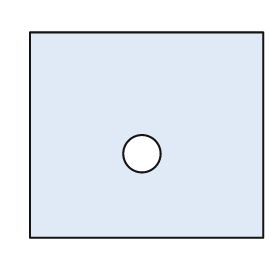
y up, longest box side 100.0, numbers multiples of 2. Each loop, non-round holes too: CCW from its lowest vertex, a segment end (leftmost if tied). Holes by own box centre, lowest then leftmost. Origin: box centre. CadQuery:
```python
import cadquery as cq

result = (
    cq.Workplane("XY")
    .moveTo(-50.0, -44.0)
    .lineTo(50.0, -44.0)
    .lineTo(50.0, 44.0)
    .lineTo(-50.0, 44.0)
    .close()
    .moveTo(-2.0, -8.0)
    .circle(8.0)
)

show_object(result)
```